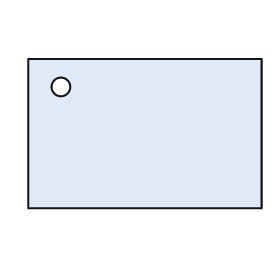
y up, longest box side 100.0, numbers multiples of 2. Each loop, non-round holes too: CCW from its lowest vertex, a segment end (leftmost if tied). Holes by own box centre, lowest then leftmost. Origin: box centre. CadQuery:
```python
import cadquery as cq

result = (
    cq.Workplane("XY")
    .moveTo(-50.0, -32.0)
    .lineTo(50.0, -32.0)
    .lineTo(50.0, 32.0)
    .lineTo(-50.0, 32.0)
    .close()
    .moveTo(-36.0, 20.0)
    .circle(4.0)
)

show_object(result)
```